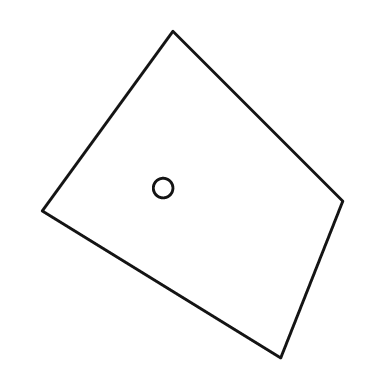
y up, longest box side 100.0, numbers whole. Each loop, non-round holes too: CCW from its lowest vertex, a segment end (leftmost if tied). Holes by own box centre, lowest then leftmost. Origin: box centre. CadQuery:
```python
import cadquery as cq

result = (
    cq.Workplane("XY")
    .moveTo(27.0, -50.0)
    .lineTo(46.0, -2.0)
    .lineTo(-6.0, 50.0)
    .lineTo(-46.0, -5.0)
    .close()
    .moveTo(-9.0, 2.0)
    .circle(3.0)
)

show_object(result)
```